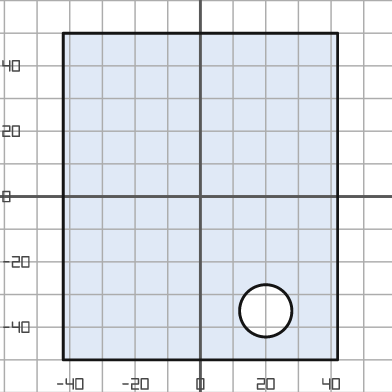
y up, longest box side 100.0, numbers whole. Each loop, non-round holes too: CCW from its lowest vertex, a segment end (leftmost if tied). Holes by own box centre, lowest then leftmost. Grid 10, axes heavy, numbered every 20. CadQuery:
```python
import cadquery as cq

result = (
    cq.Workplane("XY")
    .moveTo(-42.0, -50.0)
    .lineTo(42.0, -50.0)
    .lineTo(42.0, 50.0)
    .lineTo(-42.0, 50.0)
    .close()
    .moveTo(20.0, -35.0)
    .circle(8.0)
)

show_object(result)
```